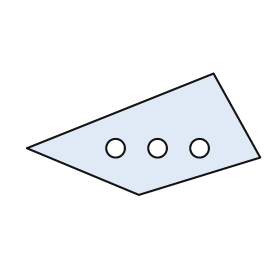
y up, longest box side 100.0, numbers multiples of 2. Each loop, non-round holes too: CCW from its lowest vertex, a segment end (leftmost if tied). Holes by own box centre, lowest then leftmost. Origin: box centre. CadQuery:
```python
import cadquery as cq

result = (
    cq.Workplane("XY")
    .moveTo(-2.0, -26.0)
    .lineTo(50.0, -10.0)
    .lineTo(30.0, 26.0)
    .lineTo(-50.0, -6.0)
    .close()
    .moveTo(-12.0, -6.0)
    .circle(4.0)
    .moveTo(6.0, -6.0)
    .circle(4.0)
    .moveTo(24.0, -6.0)
    .circle(4.0)
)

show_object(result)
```